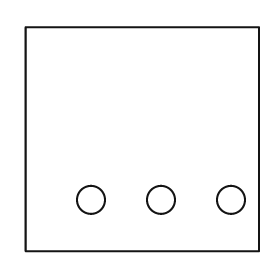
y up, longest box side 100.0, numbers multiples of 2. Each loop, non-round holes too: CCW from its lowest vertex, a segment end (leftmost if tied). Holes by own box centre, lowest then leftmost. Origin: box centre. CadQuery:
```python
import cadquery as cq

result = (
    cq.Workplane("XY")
    .moveTo(-50.0, -48.0)
    .lineTo(50.0, -48.0)
    .lineTo(50.0, 48.0)
    .lineTo(-50.0, 48.0)
    .close()
    .moveTo(-22.0, -26.0)
    .circle(6.0)
    .moveTo(8.0, -26.0)
    .circle(6.0)
    .moveTo(38.0, -26.0)
    .circle(6.0)
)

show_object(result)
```